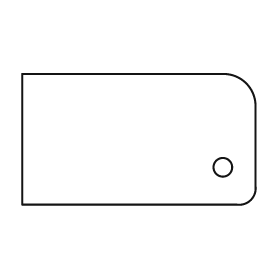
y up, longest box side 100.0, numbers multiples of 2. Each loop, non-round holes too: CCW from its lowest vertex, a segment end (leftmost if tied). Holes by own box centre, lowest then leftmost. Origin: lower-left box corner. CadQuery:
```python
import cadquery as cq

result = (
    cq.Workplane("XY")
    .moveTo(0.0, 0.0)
    .lineTo(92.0, 0.0)
    .threePointArc((98.0, 2.0), (100.0, 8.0))
    .lineTo(100.0, 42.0)
    .threePointArc((96.0, 52.0), (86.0, 56.0))
    .lineTo(0.0, 56.0)
    .close()
    .moveTo(86.0, 16.0)
    .circle(4.0)
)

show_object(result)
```